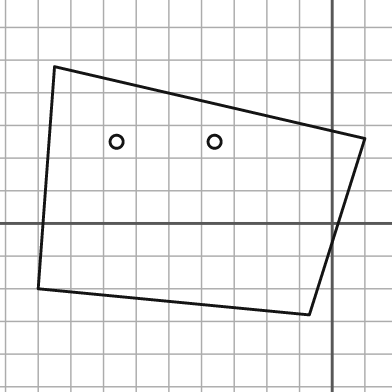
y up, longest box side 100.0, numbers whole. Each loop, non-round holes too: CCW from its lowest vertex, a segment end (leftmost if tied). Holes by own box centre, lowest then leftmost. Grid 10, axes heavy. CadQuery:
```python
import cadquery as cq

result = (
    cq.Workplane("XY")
    .moveTo(-7.0, -28.0)
    .lineTo(10.0, 26.0)
    .lineTo(-85.0, 48.0)
    .lineTo(-90.0, -20.0)
    .close()
    .moveTo(-66.0, 25.0)
    .circle(2.0)
    .moveTo(-36.0, 25.0)
    .circle(2.0)
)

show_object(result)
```